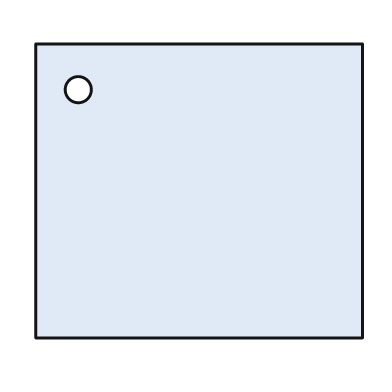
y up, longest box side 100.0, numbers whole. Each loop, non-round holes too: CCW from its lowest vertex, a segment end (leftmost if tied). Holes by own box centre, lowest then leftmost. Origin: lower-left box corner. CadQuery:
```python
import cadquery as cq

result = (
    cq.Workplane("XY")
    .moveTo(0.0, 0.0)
    .lineTo(100.0, 0.0)
    .lineTo(100.0, 90.0)
    .lineTo(0.0, 90.0)
    .close()
    .moveTo(13.0, 76.0)
    .circle(4.0)
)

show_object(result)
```